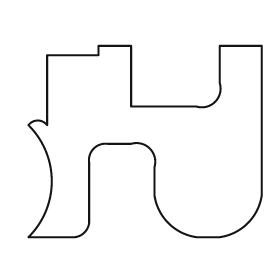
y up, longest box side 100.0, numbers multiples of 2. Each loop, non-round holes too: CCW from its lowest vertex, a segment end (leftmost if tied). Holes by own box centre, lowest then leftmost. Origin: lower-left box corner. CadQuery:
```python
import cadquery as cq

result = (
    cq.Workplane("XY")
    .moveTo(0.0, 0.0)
    .lineTo(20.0, 0.0)
    .threePointArc((24.0, 2.0), (26.0, 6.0))
    .lineTo(26.0, 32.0)
    .threePointArc((28.0, 38.0), (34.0, 40.0))
    .lineTo(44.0, 40.0)
    .threePointArc((52.0, 38.0), (54.0, 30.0))
    .lineTo(54.0, 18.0)
    .threePointArc((60.0, 6.0), (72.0, 0.0))
    .lineTo(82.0, 0.0)
    .threePointArc((94.0, 6.0), (100.0, 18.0))
    .lineTo(100.0, 82.0)
    .lineTo(82.0, 82.0)
    .lineTo(82.0, 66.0)
    .threePointArc((80.0, 58.0), (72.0, 56.0))
    .lineTo(44.0, 56.0)
    .lineTo(44.0, 82.0)
    .lineTo(30.0, 82.0)
    .lineTo(30.0, 78.0)
    .lineTo(8.0, 78.0)
    .lineTo(8.0, 48.0)
    .threePointArc((4.0, 50.0), (0.0, 48.0))
    .threePointArc((10.0, 24.0), (0.0, 0.0))
    .close()
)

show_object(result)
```